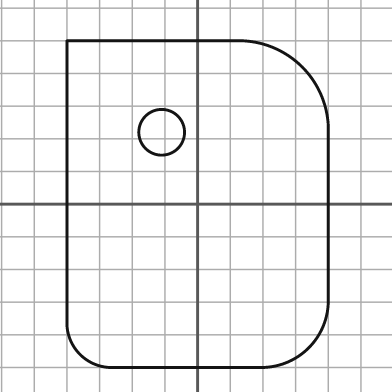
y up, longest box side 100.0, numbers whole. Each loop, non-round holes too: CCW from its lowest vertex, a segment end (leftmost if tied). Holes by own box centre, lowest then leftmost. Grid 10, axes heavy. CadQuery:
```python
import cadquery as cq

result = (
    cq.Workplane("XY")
    .moveTo(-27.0, -50.0)
    .lineTo(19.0, -50.0)
    .threePointArc((34.0, -44.0), (40.0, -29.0))
    .lineTo(40.0, 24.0)
    .threePointArc((32.0, 42.0), (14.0, 50.0))
    .lineTo(-40.0, 50.0)
    .lineTo(-40.0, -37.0)
    .threePointArc((-36.0, -46.0), (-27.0, -50.0))
    .close()
    .moveTo(-11.0, 22.0)
    .circle(7.0)
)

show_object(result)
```